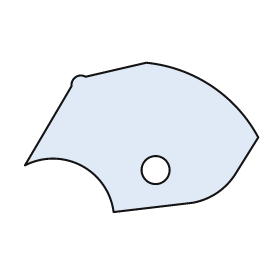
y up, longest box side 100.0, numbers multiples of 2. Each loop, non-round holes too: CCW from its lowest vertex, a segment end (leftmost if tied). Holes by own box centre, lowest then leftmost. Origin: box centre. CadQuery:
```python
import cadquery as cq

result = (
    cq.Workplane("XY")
    .moveTo(-12.0, -32.0)
    .lineTo(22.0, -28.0)
    .threePointArc((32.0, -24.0), (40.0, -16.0))
    .lineTo(50.0, 0.0)
    .threePointArc((30.0, 22.0), (2.0, 32.0))
    .lineTo(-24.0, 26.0)
    .threePointArc((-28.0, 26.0), (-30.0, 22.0))
    .lineTo(-50.0, -12.0)
    .threePointArc((-26.0, -12.0), (-12.0, -32.0))
    .close()
    .moveTo(6.0, -14.0)
    .circle(6.0)
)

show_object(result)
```